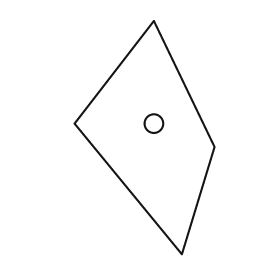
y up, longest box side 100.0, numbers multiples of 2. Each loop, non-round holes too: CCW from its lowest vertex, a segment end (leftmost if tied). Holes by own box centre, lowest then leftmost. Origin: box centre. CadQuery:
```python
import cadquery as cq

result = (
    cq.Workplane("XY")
    .moveTo(16.0, -50.0)
    .lineTo(30.0, -4.0)
    .lineTo(4.0, 50.0)
    .lineTo(-30.0, 6.0)
    .close()
    .moveTo(4.0, 6.0)
    .circle(4.0)
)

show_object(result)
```